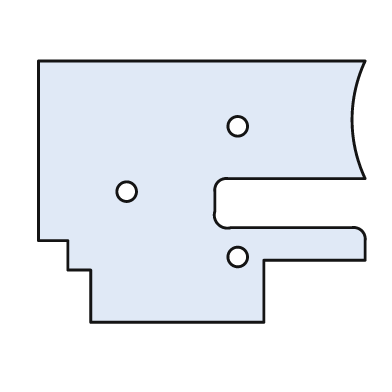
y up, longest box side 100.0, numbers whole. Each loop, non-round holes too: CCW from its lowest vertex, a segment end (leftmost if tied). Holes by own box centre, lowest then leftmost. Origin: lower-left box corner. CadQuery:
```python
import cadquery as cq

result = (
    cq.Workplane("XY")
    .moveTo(16.0, 0.0)
    .lineTo(69.0, 0.0)
    .lineTo(69.0, 19.0)
    .lineTo(100.0, 19.0)
    .lineTo(100.0, 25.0)
    .threePointArc((99.0, 28.0), (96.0, 29.0))
    .lineTo(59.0, 29.0)
    .threePointArc((55.0, 30.0), (54.0, 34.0))
    .lineTo(54.0, 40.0)
    .threePointArc((55.0, 43.0), (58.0, 44.0))
    .lineTo(100.0, 44.0)
    .threePointArc((96.0, 62.0), (100.0, 80.0))
    .lineTo(0.0, 80.0)
    .lineTo(0.0, 25.0)
    .lineTo(9.0, 25.0)
    .lineTo(9.0, 16.0)
    .lineTo(16.0, 16.0)
    .close()
    .moveTo(61.0, 20.0)
    .circle(3.0)
    .moveTo(27.0, 40.0)
    .circle(3.0)
    .moveTo(61.0, 60.0)
    .circle(3.0)
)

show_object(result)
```